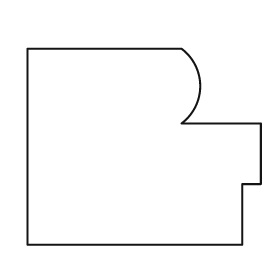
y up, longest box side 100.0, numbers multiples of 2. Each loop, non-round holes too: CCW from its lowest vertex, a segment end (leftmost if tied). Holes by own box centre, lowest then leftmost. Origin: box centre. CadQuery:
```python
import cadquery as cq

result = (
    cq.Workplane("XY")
    .moveTo(-50.0, -42.0)
    .lineTo(42.0, -42.0)
    .lineTo(42.0, -16.0)
    .lineTo(50.0, -16.0)
    .lineTo(50.0, 10.0)
    .lineTo(16.0, 10.0)
    .threePointArc((24.0, 26.0), (16.0, 42.0))
    .lineTo(-50.0, 42.0)
    .close()
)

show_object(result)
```